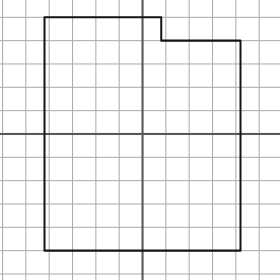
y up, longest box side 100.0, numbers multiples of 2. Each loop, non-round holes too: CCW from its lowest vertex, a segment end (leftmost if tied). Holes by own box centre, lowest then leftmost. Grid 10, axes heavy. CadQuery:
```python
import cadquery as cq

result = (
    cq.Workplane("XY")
    .moveTo(-42.0, -50.0)
    .lineTo(42.0, -50.0)
    .lineTo(42.0, 40.0)
    .lineTo(8.0, 40.0)
    .lineTo(8.0, 50.0)
    .lineTo(-42.0, 50.0)
    .close()
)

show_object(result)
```